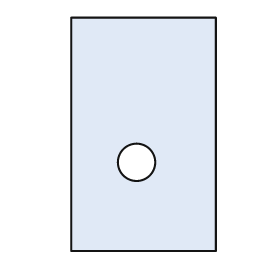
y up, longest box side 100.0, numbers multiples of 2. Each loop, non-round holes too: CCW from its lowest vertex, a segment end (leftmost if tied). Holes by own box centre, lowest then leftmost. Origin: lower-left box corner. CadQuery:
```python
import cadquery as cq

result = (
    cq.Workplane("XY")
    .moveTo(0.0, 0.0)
    .lineTo(62.0, 0.0)
    .lineTo(62.0, 100.0)
    .lineTo(0.0, 100.0)
    .close()
    .moveTo(28.0, 38.0)
    .circle(8.0)
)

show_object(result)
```